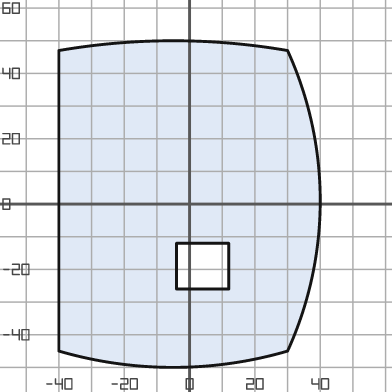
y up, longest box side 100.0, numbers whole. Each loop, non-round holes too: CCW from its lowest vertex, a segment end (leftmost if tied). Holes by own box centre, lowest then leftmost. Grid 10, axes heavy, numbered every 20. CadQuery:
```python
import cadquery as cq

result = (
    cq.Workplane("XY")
    .moveTo(-40.0, -45.0)
    .threePointArc((-5.0, -50.0), (30.0, -45.0))
    .threePointArc((40.0, 1.0), (30.0, 47.0))
    .threePointArc((-5.0, 50.0), (-40.0, 47.0))
    .close()
    .moveTo(-4.0, -26.0)
    .lineTo(12.0, -26.0)
    .lineTo(12.0, -12.0)
    .lineTo(-4.0, -12.0)
    .close()
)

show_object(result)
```